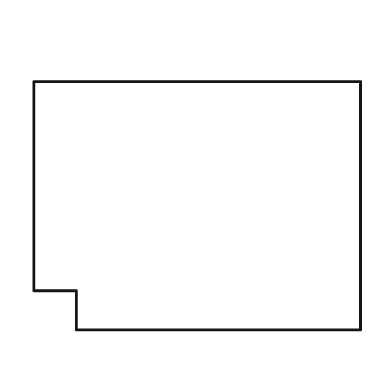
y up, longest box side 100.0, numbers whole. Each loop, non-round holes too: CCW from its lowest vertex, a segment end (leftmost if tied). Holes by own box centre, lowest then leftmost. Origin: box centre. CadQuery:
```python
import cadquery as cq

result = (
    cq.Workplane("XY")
    .moveTo(-37.0, -38.0)
    .lineTo(50.0, -38.0)
    .lineTo(50.0, 38.0)
    .lineTo(-50.0, 38.0)
    .lineTo(-50.0, -26.0)
    .lineTo(-37.0, -26.0)
    .close()
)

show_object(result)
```